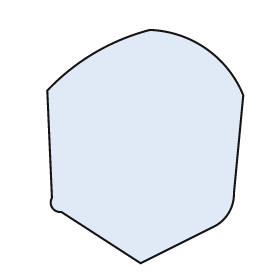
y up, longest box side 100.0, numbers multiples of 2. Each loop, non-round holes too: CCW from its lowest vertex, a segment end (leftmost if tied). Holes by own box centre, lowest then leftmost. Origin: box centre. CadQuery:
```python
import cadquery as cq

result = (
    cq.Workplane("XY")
    .moveTo(-2.0, -50.0)
    .lineTo(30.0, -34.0)
    .threePointArc((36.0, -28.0), (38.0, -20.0))
    .lineTo(42.0, 22.0)
    .threePointArc((26.0, 42.0), (2.0, 50.0))
    .threePointArc((-22.0, 40.0), (-42.0, 24.0))
    .lineTo(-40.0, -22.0)
    .threePointArc((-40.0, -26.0), (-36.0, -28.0))
    .close()
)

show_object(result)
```